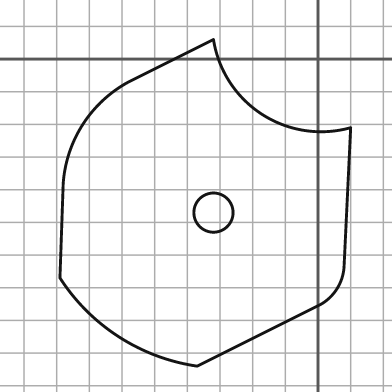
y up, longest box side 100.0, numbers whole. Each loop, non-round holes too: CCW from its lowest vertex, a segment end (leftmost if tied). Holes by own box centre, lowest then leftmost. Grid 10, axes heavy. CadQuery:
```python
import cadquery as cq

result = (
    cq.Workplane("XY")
    .moveTo(-37.0, -94.0)
    .lineTo(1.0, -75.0)
    .threePointArc((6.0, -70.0), (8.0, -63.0))
    .lineTo(10.0, -21.0)
    .threePointArc((-17.0, -17.0), (-32.0, 6.0))
    .lineTo(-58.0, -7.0)
    .threePointArc((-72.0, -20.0), (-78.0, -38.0))
    .lineTo(-79.0, -67.0)
    .threePointArc((-61.0, -85.0), (-37.0, -94.0))
    .close()
    .moveTo(-32.0, -47.0)
    .circle(6.0)
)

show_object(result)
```